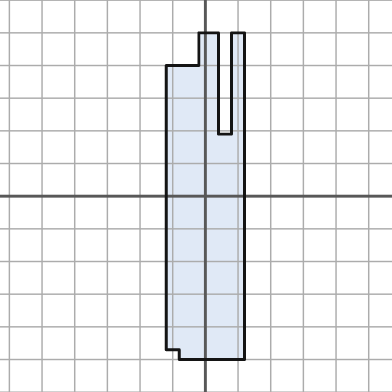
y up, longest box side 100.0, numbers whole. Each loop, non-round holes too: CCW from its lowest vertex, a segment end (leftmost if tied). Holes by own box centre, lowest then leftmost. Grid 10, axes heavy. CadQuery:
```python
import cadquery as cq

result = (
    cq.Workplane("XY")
    .moveTo(-8.0, -50.0)
    .lineTo(12.0, -50.0)
    .lineTo(12.0, 50.0)
    .lineTo(8.0, 50.0)
    .lineTo(8.0, 19.0)
    .lineTo(4.0, 19.0)
    .lineTo(4.0, 50.0)
    .lineTo(-2.0, 50.0)
    .lineTo(-2.0, 40.0)
    .lineTo(-12.0, 40.0)
    .lineTo(-12.0, -47.0)
    .lineTo(-8.0, -47.0)
    .close()
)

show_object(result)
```